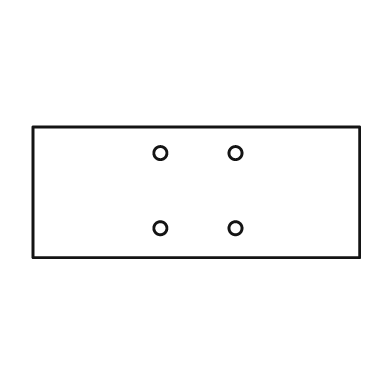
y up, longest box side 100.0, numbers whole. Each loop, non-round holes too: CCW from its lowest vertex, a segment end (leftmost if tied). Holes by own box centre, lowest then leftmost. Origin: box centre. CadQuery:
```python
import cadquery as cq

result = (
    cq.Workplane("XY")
    .moveTo(-50.0, -20.0)
    .lineTo(50.0, -20.0)
    .lineTo(50.0, 20.0)
    .lineTo(-50.0, 20.0)
    .close()
    .moveTo(-11.0, -11.0)
    .circle(2.0)
    .moveTo(12.0, -11.0)
    .circle(2.0)
    .moveTo(-11.0, 12.0)
    .circle(2.0)
    .moveTo(12.0, 12.0)
    .circle(2.0)
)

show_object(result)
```